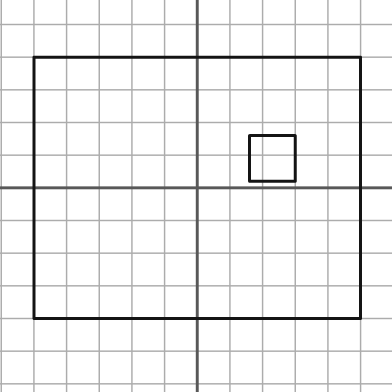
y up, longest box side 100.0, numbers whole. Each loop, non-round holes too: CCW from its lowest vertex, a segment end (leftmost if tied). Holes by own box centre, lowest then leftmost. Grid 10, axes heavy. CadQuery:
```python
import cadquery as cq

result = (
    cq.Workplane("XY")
    .moveTo(-50.0, -40.0)
    .lineTo(50.0, -40.0)
    .lineTo(50.0, 40.0)
    .lineTo(-50.0, 40.0)
    .close()
    .moveTo(16.0, 2.0)
    .lineTo(30.0, 2.0)
    .lineTo(30.0, 16.0)
    .lineTo(16.0, 16.0)
    .close()
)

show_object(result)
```